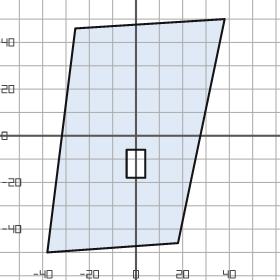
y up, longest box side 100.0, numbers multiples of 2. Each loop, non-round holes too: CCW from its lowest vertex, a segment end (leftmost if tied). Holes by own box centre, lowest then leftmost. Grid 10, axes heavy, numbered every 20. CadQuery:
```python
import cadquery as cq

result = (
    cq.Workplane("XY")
    .moveTo(-38.0, -50.0)
    .lineTo(18.0, -46.0)
    .lineTo(38.0, 50.0)
    .lineTo(-26.0, 46.0)
    .close()
    .moveTo(-4.0, -18.0)
    .lineTo(4.0, -18.0)
    .lineTo(4.0, -6.0)
    .lineTo(-4.0, -6.0)
    .close()
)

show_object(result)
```